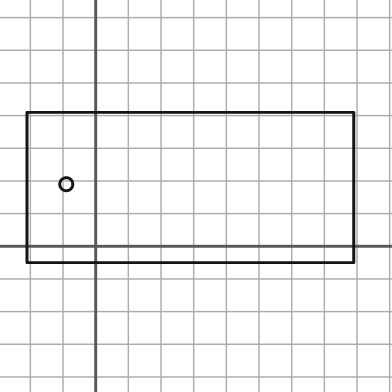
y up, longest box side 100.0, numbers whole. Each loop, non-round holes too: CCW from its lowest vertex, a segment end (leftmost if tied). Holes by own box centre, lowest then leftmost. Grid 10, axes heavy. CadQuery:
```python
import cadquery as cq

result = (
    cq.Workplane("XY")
    .moveTo(-21.0, -5.0)
    .lineTo(79.0, -5.0)
    .lineTo(79.0, 41.0)
    .lineTo(-21.0, 41.0)
    .close()
    .moveTo(-9.0, 19.0)
    .circle(2.0)
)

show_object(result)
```